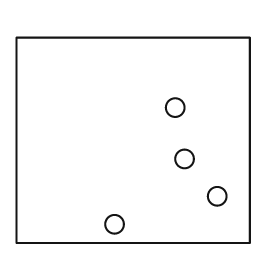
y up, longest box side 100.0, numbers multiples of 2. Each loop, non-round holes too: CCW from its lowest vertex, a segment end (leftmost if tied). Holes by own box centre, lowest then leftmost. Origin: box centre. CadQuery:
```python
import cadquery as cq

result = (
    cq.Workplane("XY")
    .moveTo(-50.0, -44.0)
    .lineTo(50.0, -44.0)
    .lineTo(50.0, 44.0)
    .lineTo(-50.0, 44.0)
    .close()
    .moveTo(-8.0, -36.0)
    .circle(4.0)
    .moveTo(36.0, -24.0)
    .circle(4.0)
    .moveTo(22.0, -8.0)
    .circle(4.0)
    .moveTo(18.0, 14.0)
    .circle(4.0)
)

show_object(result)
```